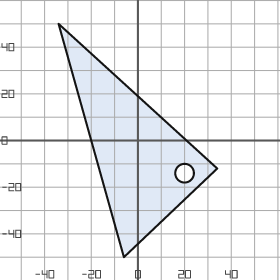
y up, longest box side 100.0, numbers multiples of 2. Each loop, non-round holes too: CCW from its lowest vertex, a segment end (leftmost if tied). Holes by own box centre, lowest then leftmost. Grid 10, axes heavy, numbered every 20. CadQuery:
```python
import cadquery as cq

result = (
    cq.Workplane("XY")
    .moveTo(-6.0, -50.0)
    .lineTo(34.0, -12.0)
    .lineTo(-34.0, 50.0)
    .close()
    .moveTo(20.0, -14.0)
    .circle(4.0)
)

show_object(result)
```